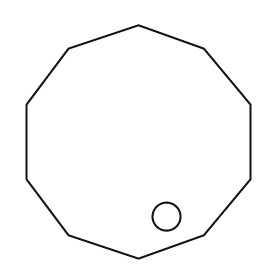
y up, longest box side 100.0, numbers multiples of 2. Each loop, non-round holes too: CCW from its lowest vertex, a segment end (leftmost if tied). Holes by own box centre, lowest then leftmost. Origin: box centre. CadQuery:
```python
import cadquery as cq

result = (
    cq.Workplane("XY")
    .moveTo(0.0, -50.0)
    .lineTo(28.0, -40.0)
    .lineTo(48.0, -16.0)
    .lineTo(48.0, 16.0)
    .lineTo(28.0, 40.0)
    .lineTo(0.0, 50.0)
    .lineTo(-30.0, 40.0)
    .lineTo(-48.0, 16.0)
    .lineTo(-48.0, -16.0)
    .lineTo(-30.0, -40.0)
    .close()
    .moveTo(12.0, -32.0)
    .circle(6.0)
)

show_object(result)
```